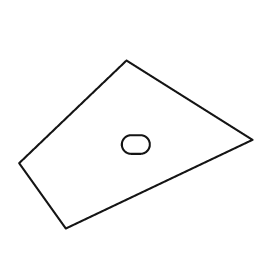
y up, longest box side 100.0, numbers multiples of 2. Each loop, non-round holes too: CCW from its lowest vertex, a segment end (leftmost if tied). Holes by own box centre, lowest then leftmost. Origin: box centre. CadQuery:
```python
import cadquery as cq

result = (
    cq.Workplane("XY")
    .moveTo(-30.0, -36.0)
    .lineTo(50.0, 2.0)
    .lineTo(-4.0, 36.0)
    .lineTo(-50.0, -8.0)
    .close()
    .moveTo(-2.0, -4.0)
    .lineTo(2.0, -4.0)
    .threePointArc((6.0, 0.0), (2.0, 4.0))
    .lineTo(-2.0, 4.0)
    .threePointArc((-6.0, 0.0), (-2.0, -4.0))
    .close()
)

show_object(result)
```